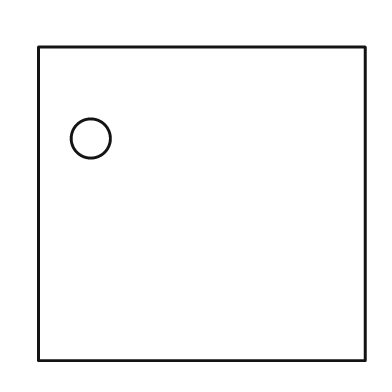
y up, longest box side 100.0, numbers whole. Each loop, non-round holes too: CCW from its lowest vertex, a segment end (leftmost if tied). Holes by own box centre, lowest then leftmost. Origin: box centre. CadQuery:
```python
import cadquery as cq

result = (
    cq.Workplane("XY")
    .moveTo(-50.0, -48.0)
    .lineTo(50.0, -48.0)
    .lineTo(50.0, 48.0)
    .lineTo(-50.0, 48.0)
    .close()
    .moveTo(-34.0, 20.0)
    .circle(6.0)
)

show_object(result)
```